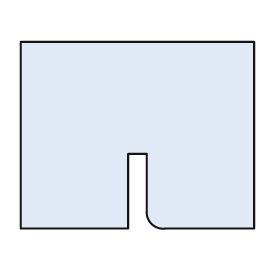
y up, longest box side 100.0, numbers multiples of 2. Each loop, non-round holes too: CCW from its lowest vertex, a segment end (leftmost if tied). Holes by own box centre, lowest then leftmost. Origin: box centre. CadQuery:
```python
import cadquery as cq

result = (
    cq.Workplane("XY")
    .moveTo(-50.0, -40.0)
    .lineTo(-4.0, -40.0)
    .lineTo(-4.0, -8.0)
    .lineTo(4.0, -8.0)
    .lineTo(4.0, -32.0)
    .threePointArc((6.0, -38.0), (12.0, -40.0))
    .lineTo(50.0, -40.0)
    .lineTo(50.0, 40.0)
    .lineTo(-50.0, 40.0)
    .close()
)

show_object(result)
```